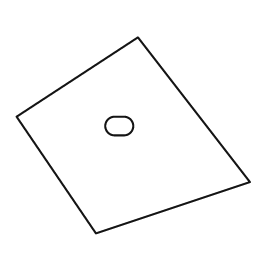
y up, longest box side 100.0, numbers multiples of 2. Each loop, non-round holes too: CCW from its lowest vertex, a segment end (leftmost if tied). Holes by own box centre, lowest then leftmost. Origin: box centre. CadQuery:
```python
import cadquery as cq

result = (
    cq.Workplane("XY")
    .moveTo(-16.0, -42.0)
    .lineTo(50.0, -20.0)
    .lineTo(2.0, 42.0)
    .lineTo(-50.0, 8.0)
    .close()
    .moveTo(-8.0, 0.0)
    .lineTo(-4.0, 0.0)
    .threePointArc((0.0, 4.0), (-4.0, 8.0))
    .lineTo(-8.0, 8.0)
    .threePointArc((-12.0, 4.0), (-8.0, 0.0))
    .close()
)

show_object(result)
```